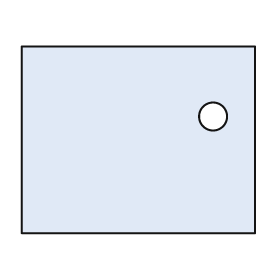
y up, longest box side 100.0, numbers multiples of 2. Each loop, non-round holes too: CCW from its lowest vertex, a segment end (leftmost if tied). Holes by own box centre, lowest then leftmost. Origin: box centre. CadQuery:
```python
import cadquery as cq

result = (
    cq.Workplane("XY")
    .moveTo(-50.0, -40.0)
    .lineTo(50.0, -40.0)
    .lineTo(50.0, 40.0)
    .lineTo(-50.0, 40.0)
    .close()
    .moveTo(32.0, 10.0)
    .circle(6.0)
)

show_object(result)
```